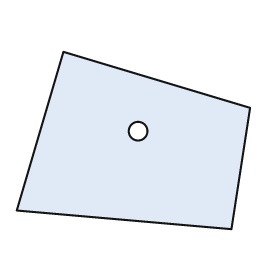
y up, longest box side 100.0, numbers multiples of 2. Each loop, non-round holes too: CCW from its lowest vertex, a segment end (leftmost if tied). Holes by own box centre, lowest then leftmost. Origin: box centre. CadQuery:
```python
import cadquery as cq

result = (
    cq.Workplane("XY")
    .moveTo(42.0, -38.0)
    .lineTo(50.0, 14.0)
    .lineTo(-30.0, 38.0)
    .lineTo(-50.0, -30.0)
    .close()
    .moveTo(2.0, 4.0)
    .circle(4.0)
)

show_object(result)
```